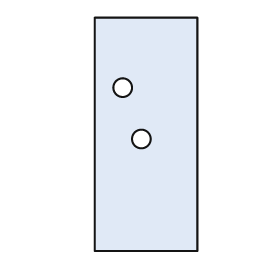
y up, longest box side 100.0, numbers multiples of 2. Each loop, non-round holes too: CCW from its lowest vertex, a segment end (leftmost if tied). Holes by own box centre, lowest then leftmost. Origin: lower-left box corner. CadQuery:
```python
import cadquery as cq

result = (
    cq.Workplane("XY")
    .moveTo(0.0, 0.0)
    .lineTo(44.0, 0.0)
    .lineTo(44.0, 100.0)
    .lineTo(0.0, 100.0)
    .close()
    .moveTo(20.0, 48.0)
    .circle(4.0)
    .moveTo(12.0, 70.0)
    .circle(4.0)
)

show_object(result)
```